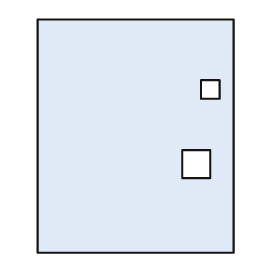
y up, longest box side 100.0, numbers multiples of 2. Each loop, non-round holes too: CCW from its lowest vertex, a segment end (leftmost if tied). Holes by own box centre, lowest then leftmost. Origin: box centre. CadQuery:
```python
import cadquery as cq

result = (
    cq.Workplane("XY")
    .moveTo(-42.0, -50.0)
    .lineTo(42.0, -50.0)
    .lineTo(42.0, 50.0)
    .lineTo(-42.0, 50.0)
    .close()
    .moveTo(20.0, -18.0)
    .lineTo(32.0, -18.0)
    .lineTo(32.0, -6.0)
    .lineTo(20.0, -6.0)
    .close()
    .moveTo(28.0, 16.0)
    .lineTo(36.0, 16.0)
    .lineTo(36.0, 24.0)
    .lineTo(28.0, 24.0)
    .close()
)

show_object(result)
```